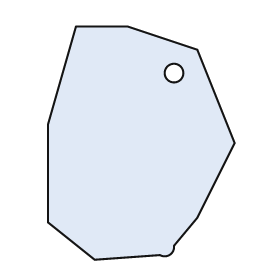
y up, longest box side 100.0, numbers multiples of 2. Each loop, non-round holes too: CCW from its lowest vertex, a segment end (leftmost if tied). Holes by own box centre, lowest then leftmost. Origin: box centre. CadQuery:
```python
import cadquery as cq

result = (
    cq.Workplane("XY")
    .moveTo(-20.0, -50.0)
    .lineTo(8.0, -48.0)
    .threePointArc((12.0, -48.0), (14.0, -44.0))
    .lineTo(24.0, -32.0)
    .lineTo(40.0, 0.0)
    .lineTo(24.0, 40.0)
    .lineTo(-6.0, 50.0)
    .lineTo(-28.0, 50.0)
    .lineTo(-40.0, 8.0)
    .lineTo(-40.0, -34.0)
    .close()
    .moveTo(14.0, 30.0)
    .circle(4.0)
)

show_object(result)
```